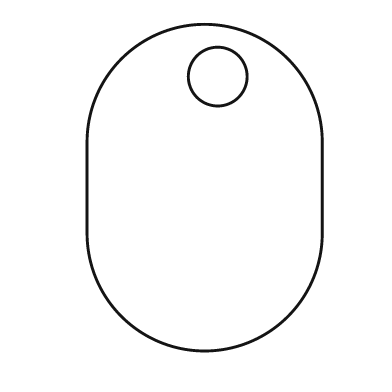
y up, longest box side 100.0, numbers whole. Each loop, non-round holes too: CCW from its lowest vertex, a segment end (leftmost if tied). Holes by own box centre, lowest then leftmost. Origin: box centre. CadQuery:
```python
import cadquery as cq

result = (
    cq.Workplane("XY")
    .moveTo(-36.0, -14.0)
    .threePointArc((0.0, -50.0), (36.0, -14.0))
    .lineTo(36.0, 14.0)
    .threePointArc((0.0, 50.0), (-36.0, 14.0))
    .close()
    .moveTo(4.0, 34.0)
    .circle(9.0)
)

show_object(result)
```